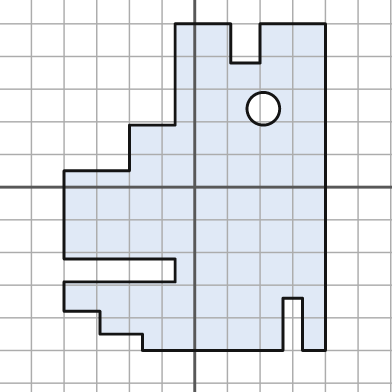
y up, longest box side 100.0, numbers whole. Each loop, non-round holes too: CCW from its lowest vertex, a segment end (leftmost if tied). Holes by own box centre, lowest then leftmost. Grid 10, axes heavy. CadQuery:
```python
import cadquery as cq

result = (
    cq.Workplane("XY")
    .moveTo(-16.0, -50.0)
    .lineTo(27.0, -50.0)
    .lineTo(27.0, -34.0)
    .lineTo(33.0, -34.0)
    .lineTo(33.0, -50.0)
    .lineTo(40.0, -50.0)
    .lineTo(40.0, 50.0)
    .lineTo(20.0, 50.0)
    .lineTo(20.0, 38.0)
    .lineTo(11.0, 38.0)
    .lineTo(11.0, 50.0)
    .lineTo(-6.0, 50.0)
    .lineTo(-6.0, 19.0)
    .lineTo(-20.0, 19.0)
    .lineTo(-20.0, 5.0)
    .lineTo(-40.0, 5.0)
    .lineTo(-40.0, -22.0)
    .lineTo(-6.0, -22.0)
    .lineTo(-6.0, -29.0)
    .lineTo(-40.0, -29.0)
    .lineTo(-40.0, -38.0)
    .lineTo(-29.0, -38.0)
    .lineTo(-29.0, -45.0)
    .lineTo(-16.0, -45.0)
    .close()
    .moveTo(21.0, 24.0)
    .circle(5.0)
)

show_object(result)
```